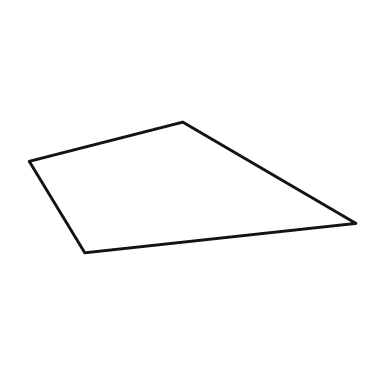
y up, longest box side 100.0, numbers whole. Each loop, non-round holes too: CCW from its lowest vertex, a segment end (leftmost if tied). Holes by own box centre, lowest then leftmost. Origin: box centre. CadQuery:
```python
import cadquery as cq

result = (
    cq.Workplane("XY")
    .moveTo(-33.0, -20.0)
    .lineTo(50.0, -11.0)
    .lineTo(-3.0, 20.0)
    .lineTo(-50.0, 8.0)
    .close()
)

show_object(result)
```